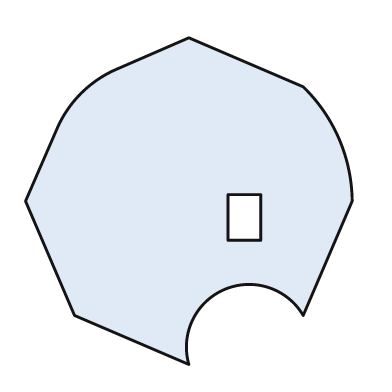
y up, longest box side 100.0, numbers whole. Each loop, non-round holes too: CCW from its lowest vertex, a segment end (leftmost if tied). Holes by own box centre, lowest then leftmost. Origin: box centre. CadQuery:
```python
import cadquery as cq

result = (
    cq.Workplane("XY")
    .moveTo(0.0, -50.0)
    .threePointArc((11.0, -27.0), (35.0, -35.0))
    .lineTo(50.0, 0.0)
    .threePointArc((46.0, 19.0), (35.0, 35.0))
    .lineTo(0.0, 50.0)
    .lineTo(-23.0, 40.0)
    .threePointArc((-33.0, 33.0), (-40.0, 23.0))
    .lineTo(-50.0, 0.0)
    .lineTo(-35.0, -35.0)
    .close()
    .moveTo(12.0, -12.0)
    .lineTo(22.0, -12.0)
    .lineTo(22.0, 2.0)
    .lineTo(12.0, 2.0)
    .close()
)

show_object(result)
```